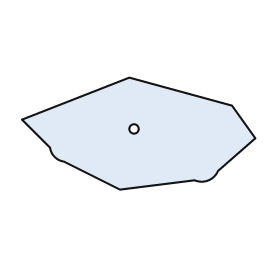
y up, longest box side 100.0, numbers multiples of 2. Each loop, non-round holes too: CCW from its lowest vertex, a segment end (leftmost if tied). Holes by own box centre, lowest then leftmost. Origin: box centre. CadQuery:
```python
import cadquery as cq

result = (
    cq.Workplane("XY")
    .moveTo(-8.0, -24.0)
    .lineTo(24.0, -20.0)
    .threePointArc((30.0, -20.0), (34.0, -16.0))
    .lineTo(50.0, -2.0)
    .lineTo(40.0, 12.0)
    .lineTo(-4.0, 24.0)
    .lineTo(-50.0, 6.0)
    .lineTo(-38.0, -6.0)
    .threePointArc((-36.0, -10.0), (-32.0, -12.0))
    .close()
    .moveTo(-2.0, 2.0)
    .circle(2.0)
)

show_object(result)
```